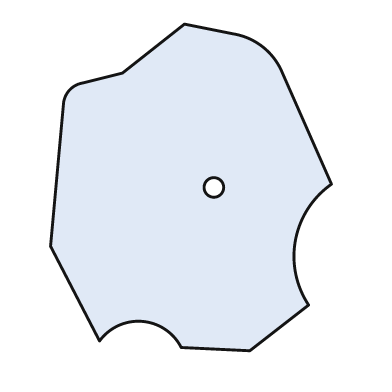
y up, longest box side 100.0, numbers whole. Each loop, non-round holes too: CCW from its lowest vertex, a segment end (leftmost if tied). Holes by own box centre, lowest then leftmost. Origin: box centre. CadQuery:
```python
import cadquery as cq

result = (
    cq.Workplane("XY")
    .moveTo(18.0, -50.0)
    .lineTo(36.0, -36.0)
    .threePointArc((32.0, -16.0), (43.0, 1.0))
    .lineTo(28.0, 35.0)
    .threePointArc((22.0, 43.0), (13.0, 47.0))
    .lineTo(-2.0, 50.0)
    .lineTo(-21.0, 35.0)
    .lineTo(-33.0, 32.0)
    .threePointArc((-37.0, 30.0), (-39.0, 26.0))
    .lineTo(-43.0, -18.0)
    .lineTo(-28.0, -47.0)
    .threePointArc((-15.0, -41.0), (-3.0, -49.0))
    .close()
    .moveTo(7.0, 0.0)
    .circle(3.0)
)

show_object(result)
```